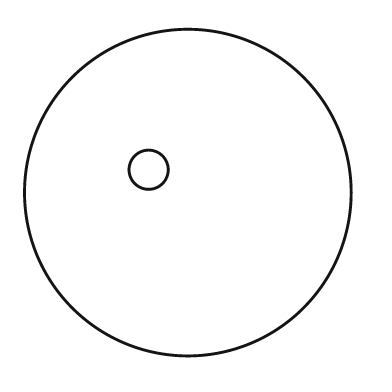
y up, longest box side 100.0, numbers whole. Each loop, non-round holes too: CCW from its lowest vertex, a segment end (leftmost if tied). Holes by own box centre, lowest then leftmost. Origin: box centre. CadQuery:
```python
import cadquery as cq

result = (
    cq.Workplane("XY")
    .moveTo(0.0, 0.0)
    .circle(50.0)
    .moveTo(-12.0, 7.0)
    .circle(6.0)
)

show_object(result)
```